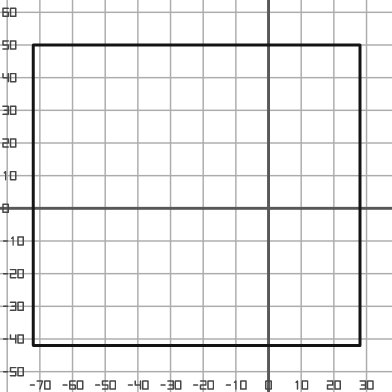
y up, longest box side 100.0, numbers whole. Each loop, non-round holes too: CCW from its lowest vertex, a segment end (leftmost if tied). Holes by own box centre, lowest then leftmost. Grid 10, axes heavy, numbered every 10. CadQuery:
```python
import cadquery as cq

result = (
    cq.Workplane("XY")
    .moveTo(-72.0, -42.0)
    .lineTo(28.0, -42.0)
    .lineTo(28.0, 50.0)
    .lineTo(-72.0, 50.0)
    .close()
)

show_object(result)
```